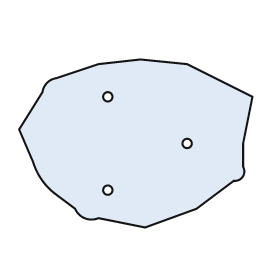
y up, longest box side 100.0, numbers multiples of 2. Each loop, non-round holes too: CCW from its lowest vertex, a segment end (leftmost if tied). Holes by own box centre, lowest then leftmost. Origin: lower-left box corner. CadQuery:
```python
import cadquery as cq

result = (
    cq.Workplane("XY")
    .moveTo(54.0, 0.0)
    .lineTo(76.0, 8.0)
    .lineTo(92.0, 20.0)
    .threePointArc((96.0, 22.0), (96.0, 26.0))
    .lineTo(96.0, 36.0)
    .lineTo(100.0, 56.0)
    .lineTo(72.0, 70.0)
    .lineTo(52.0, 72.0)
    .lineTo(34.0, 70.0)
    .lineTo(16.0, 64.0)
    .threePointArc((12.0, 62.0), (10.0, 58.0))
    .lineTo(0.0, 42.0)
    .lineTo(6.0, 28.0)
    .threePointArc((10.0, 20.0), (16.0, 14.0))
    .lineTo(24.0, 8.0)
    .threePointArc((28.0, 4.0), (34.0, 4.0))
    .close()
    .moveTo(38.0, 16.0)
    .circle(2.0)
    .moveTo(72.0, 36.0)
    .circle(2.0)
    .moveTo(38.0, 56.0)
    .circle(2.0)
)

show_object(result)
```